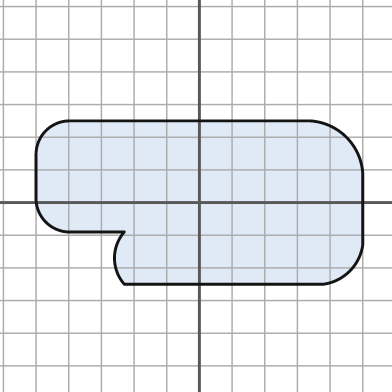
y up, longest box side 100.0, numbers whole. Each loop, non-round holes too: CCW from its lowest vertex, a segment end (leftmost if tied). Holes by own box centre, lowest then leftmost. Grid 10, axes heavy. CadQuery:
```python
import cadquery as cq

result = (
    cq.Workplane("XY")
    .moveTo(-23.0, -25.0)
    .lineTo(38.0, -25.0)
    .threePointArc((46.0, -21.0), (50.0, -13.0))
    .lineTo(50.0, 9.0)
    .threePointArc((45.0, 20.0), (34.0, 25.0))
    .lineTo(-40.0, 25.0)
    .threePointArc((-47.0, 22.0), (-50.0, 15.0))
    .lineTo(-50.0, 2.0)
    .threePointArc((-47.0, -6.0), (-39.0, -9.0))
    .lineTo(-23.0, -9.0)
    .threePointArc((-26.0, -17.0), (-23.0, -25.0))
    .close()
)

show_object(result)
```